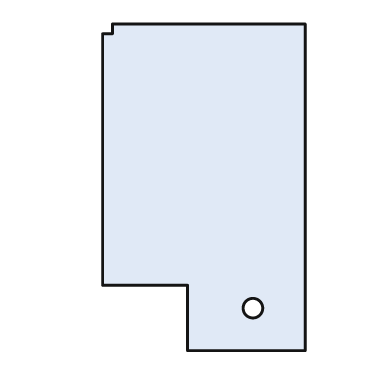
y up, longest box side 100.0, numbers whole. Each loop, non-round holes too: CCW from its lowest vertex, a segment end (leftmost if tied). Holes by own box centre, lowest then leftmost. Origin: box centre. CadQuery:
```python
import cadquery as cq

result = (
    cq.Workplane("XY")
    .moveTo(-5.0, -50.0)
    .lineTo(31.0, -50.0)
    .lineTo(31.0, 50.0)
    .lineTo(-28.0, 50.0)
    .lineTo(-28.0, 47.0)
    .lineTo(-31.0, 47.0)
    .lineTo(-31.0, -30.0)
    .lineTo(-5.0, -30.0)
    .close()
    .moveTo(15.0, -37.0)
    .circle(3.0)
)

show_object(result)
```